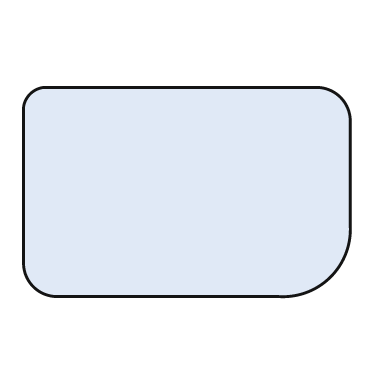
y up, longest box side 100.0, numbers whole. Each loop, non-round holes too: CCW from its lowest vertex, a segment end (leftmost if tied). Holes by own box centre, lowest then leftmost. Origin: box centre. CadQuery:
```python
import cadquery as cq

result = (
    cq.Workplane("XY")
    .moveTo(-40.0, -32.0)
    .lineTo(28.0, -32.0)
    .threePointArc((44.0, -26.0), (50.0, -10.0))
    .lineTo(50.0, 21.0)
    .threePointArc((47.0, 29.0), (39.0, 32.0))
    .lineTo(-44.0, 32.0)
    .threePointArc((-48.0, 30.0), (-50.0, 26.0))
    .lineTo(-50.0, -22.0)
    .threePointArc((-47.0, -29.0), (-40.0, -32.0))
    .close()
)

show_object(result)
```